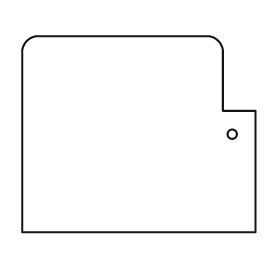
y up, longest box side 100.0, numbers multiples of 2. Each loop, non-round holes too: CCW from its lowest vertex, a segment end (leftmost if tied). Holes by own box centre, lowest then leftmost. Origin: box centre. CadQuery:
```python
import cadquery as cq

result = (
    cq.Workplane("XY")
    .moveTo(-50.0, -42.0)
    .lineTo(50.0, -42.0)
    .lineTo(50.0, 10.0)
    .lineTo(36.0, 10.0)
    .lineTo(36.0, 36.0)
    .threePointArc((34.0, 40.0), (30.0, 42.0))
    .lineTo(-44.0, 42.0)
    .threePointArc((-48.0, 40.0), (-50.0, 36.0))
    .close()
    .moveTo(40.0, 0.0)
    .circle(2.0)
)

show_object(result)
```